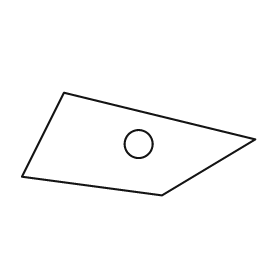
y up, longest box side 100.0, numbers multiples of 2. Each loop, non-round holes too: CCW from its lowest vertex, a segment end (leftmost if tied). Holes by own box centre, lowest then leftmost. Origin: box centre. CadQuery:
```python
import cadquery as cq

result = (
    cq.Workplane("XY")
    .moveTo(10.0, -22.0)
    .lineTo(50.0, 2.0)
    .lineTo(-32.0, 22.0)
    .lineTo(-50.0, -14.0)
    .close()
    .moveTo(0.0, 0.0)
    .circle(6.0)
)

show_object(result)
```